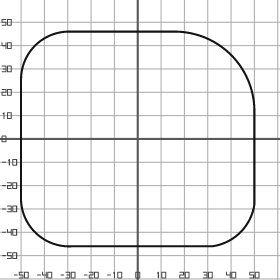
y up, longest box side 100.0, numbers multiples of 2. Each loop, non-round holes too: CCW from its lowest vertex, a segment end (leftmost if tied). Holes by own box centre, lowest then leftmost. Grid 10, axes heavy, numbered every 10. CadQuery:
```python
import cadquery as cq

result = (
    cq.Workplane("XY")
    .moveTo(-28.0, -46.0)
    .lineTo(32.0, -46.0)
    .threePointArc((44.0, -40.0), (50.0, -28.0))
    .lineTo(50.0, 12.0)
    .threePointArc((40.0, 36.0), (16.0, 46.0))
    .lineTo(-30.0, 46.0)
    .threePointArc((-44.0, 40.0), (-50.0, 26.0))
    .lineTo(-50.0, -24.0)
    .threePointArc((-44.0, -40.0), (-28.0, -46.0))
    .close()
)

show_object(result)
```